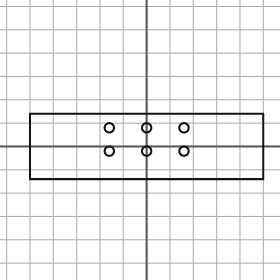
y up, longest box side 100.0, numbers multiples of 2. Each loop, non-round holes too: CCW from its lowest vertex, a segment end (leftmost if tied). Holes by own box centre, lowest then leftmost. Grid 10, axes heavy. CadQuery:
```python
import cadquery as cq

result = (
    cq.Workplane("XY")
    .moveTo(-50.0, -14.0)
    .lineTo(50.0, -14.0)
    .lineTo(50.0, 14.0)
    .lineTo(-50.0, 14.0)
    .close()
    .moveTo(-16.0, -2.0)
    .circle(2.0)
    .moveTo(0.0, -2.0)
    .circle(2.0)
    .moveTo(16.0, -2.0)
    .circle(2.0)
    .moveTo(-16.0, 8.0)
    .circle(2.0)
    .moveTo(0.0, 8.0)
    .circle(2.0)
    .moveTo(16.0, 8.0)
    .circle(2.0)
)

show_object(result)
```